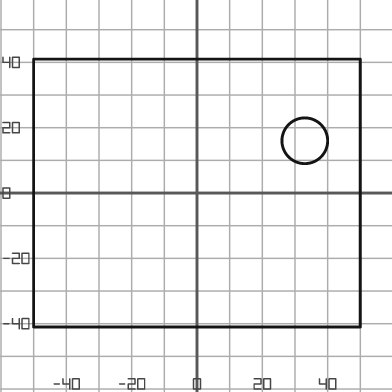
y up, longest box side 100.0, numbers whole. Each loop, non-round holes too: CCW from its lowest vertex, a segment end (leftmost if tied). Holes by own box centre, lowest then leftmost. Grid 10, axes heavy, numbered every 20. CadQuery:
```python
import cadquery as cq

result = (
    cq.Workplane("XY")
    .moveTo(-50.0, -41.0)
    .lineTo(50.0, -41.0)
    .lineTo(50.0, 41.0)
    .lineTo(-50.0, 41.0)
    .close()
    .moveTo(33.0, 16.0)
    .circle(7.0)
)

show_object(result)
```